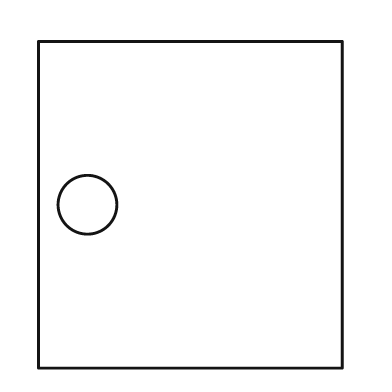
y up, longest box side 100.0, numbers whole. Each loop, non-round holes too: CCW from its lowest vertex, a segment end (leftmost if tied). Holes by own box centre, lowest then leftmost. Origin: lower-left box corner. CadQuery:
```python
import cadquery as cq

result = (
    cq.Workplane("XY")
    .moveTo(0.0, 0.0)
    .lineTo(93.0, 0.0)
    .lineTo(93.0, 100.0)
    .lineTo(0.0, 100.0)
    .close()
    .moveTo(15.0, 50.0)
    .circle(9.0)
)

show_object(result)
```